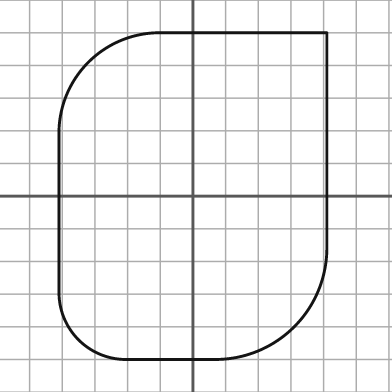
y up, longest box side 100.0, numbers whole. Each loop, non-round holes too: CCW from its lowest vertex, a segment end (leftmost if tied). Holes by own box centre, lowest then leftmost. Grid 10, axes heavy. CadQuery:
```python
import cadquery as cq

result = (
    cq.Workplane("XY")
    .moveTo(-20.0, -50.0)
    .lineTo(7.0, -50.0)
    .threePointArc((31.0, -40.0), (41.0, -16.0))
    .lineTo(41.0, 50.0)
    .lineTo(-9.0, 50.0)
    .threePointArc((-32.0, 41.0), (-41.0, 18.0))
    .lineTo(-41.0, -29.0)
    .threePointArc((-35.0, -44.0), (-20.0, -50.0))
    .close()
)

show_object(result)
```